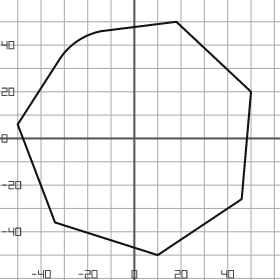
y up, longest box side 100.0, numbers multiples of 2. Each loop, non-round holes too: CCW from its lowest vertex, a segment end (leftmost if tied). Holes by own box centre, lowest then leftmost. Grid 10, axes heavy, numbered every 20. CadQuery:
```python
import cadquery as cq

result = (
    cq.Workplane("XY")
    .moveTo(10.0, -50.0)
    .lineTo(46.0, -26.0)
    .lineTo(50.0, 20.0)
    .lineTo(18.0, 50.0)
    .lineTo(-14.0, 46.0)
    .threePointArc((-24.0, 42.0), (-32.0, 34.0))
    .lineTo(-50.0, 6.0)
    .lineTo(-34.0, -36.0)
    .close()
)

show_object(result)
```